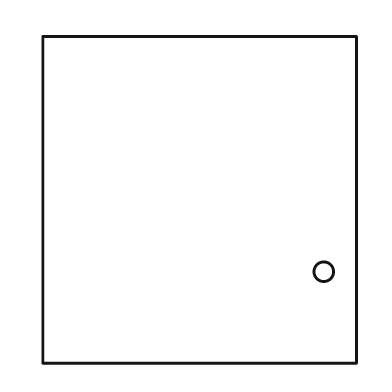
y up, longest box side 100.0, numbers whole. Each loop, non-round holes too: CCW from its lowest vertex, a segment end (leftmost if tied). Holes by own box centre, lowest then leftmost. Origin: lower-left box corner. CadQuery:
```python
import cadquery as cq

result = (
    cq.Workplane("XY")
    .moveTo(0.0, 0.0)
    .lineTo(96.0, 0.0)
    .lineTo(96.0, 100.0)
    .lineTo(0.0, 100.0)
    .close()
    .moveTo(86.0, 28.0)
    .circle(3.0)
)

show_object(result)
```